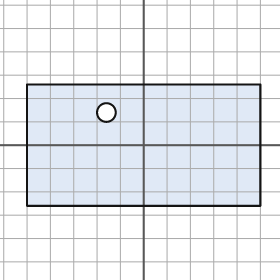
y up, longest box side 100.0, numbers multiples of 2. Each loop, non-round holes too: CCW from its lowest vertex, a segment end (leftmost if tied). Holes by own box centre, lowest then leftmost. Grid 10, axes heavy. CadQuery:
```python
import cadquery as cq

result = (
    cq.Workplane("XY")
    .moveTo(-50.0, -26.0)
    .lineTo(50.0, -26.0)
    .lineTo(50.0, 26.0)
    .lineTo(-50.0, 26.0)
    .close()
    .moveTo(-16.0, 14.0)
    .circle(4.0)
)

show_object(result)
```